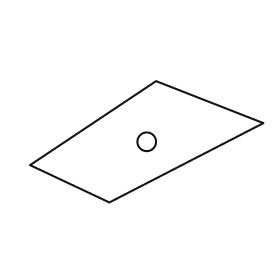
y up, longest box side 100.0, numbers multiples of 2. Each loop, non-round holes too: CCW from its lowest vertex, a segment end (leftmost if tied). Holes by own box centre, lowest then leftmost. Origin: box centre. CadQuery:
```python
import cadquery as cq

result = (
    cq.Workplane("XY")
    .moveTo(-16.0, -26.0)
    .lineTo(50.0, 8.0)
    .lineTo(4.0, 26.0)
    .lineTo(-50.0, -10.0)
    .close()
    .moveTo(0.0, 0.0)
    .circle(4.0)
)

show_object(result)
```